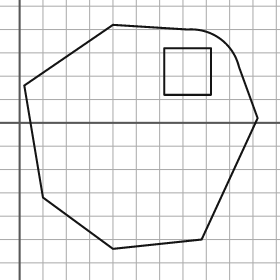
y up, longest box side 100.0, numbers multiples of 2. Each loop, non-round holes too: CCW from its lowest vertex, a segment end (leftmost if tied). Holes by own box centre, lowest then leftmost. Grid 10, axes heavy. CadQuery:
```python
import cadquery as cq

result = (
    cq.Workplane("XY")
    .moveTo(40.0, -54.0)
    .lineTo(78.0, -50.0)
    .lineTo(102.0, 2.0)
    .lineTo(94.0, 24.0)
    .threePointArc((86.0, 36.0), (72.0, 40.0))
    .lineTo(40.0, 42.0)
    .lineTo(2.0, 16.0)
    .lineTo(10.0, -32.0)
    .close()
    .moveTo(62.0, 12.0)
    .lineTo(82.0, 12.0)
    .lineTo(82.0, 32.0)
    .lineTo(62.0, 32.0)
    .close()
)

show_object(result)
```